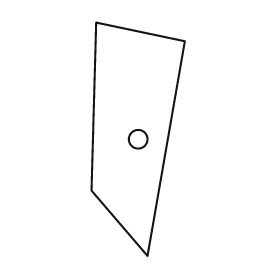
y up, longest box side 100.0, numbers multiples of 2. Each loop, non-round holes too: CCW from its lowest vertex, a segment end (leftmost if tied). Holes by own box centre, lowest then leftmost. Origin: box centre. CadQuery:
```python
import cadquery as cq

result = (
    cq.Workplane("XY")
    .moveTo(4.0, -50.0)
    .lineTo(20.0, 42.0)
    .lineTo(-18.0, 50.0)
    .lineTo(-20.0, -22.0)
    .close()
    .moveTo(0.0, 0.0)
    .circle(4.0)
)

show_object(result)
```